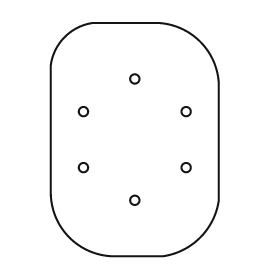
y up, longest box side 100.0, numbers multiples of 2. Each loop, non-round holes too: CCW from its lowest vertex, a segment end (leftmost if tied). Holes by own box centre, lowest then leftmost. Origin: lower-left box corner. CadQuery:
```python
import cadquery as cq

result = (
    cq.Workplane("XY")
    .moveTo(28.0, 0.0)
    .lineTo(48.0, 0.0)
    .threePointArc((64.0, 8.0), (72.0, 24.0))
    .lineTo(72.0, 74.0)
    .threePointArc((64.0, 92.0), (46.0, 100.0))
    .lineTo(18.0, 100.0)
    .threePointArc((6.0, 94.0), (0.0, 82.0))
    .lineTo(0.0, 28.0)
    .threePointArc((8.0, 8.0), (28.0, 0.0))
    .close()
    .moveTo(36.0, 24.0)
    .circle(2.0)
    .moveTo(14.0, 38.0)
    .circle(2.0)
    .moveTo(58.0, 38.0)
    .circle(2.0)
    .moveTo(14.0, 62.0)
    .circle(2.0)
    .moveTo(58.0, 62.0)
    .circle(2.0)
    .moveTo(36.0, 76.0)
    .circle(2.0)
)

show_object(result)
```